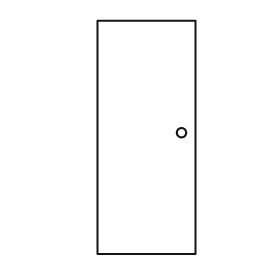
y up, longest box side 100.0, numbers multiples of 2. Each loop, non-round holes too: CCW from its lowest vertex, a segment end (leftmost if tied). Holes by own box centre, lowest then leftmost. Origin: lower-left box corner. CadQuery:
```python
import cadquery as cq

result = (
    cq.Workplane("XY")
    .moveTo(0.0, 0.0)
    .lineTo(42.0, 0.0)
    .lineTo(42.0, 100.0)
    .lineTo(0.0, 100.0)
    .close()
    .moveTo(36.0, 52.0)
    .circle(2.0)
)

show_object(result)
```